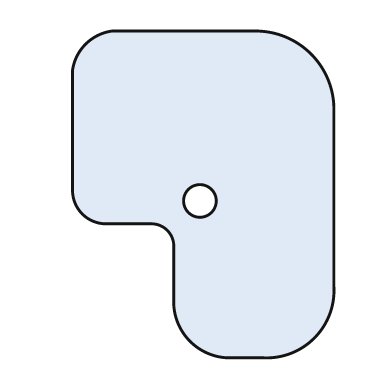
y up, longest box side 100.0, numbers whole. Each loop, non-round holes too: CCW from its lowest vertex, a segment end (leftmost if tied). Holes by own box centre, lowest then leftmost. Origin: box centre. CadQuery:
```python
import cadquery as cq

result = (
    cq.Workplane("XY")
    .moveTo(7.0, -50.0)
    .lineTo(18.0, -50.0)
    .threePointArc((34.0, -44.0), (40.0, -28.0))
    .lineTo(40.0, 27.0)
    .threePointArc((33.0, 43.0), (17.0, 50.0))
    .lineTo(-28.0, 50.0)
    .threePointArc((-36.0, 46.0), (-40.0, 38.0))
    .lineTo(-40.0, 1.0)
    .threePointArc((-37.0, -6.0), (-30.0, -9.0))
    .lineTo(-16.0, -9.0)
    .threePointArc((-11.0, -11.0), (-9.0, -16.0))
    .lineTo(-9.0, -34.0)
    .threePointArc((-4.0, -45.0), (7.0, -50.0))
    .close()
    .moveTo(-1.0, -2.0)
    .circle(5.0)
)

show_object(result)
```